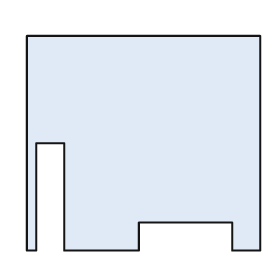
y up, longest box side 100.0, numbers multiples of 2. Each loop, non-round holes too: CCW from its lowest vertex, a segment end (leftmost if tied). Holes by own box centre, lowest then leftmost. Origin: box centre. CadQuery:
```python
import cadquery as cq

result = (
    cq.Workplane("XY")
    .moveTo(-50.0, -46.0)
    .lineTo(-46.0, -46.0)
    .lineTo(-46.0, 0.0)
    .lineTo(-34.0, 0.0)
    .lineTo(-34.0, -46.0)
    .lineTo(-2.0, -46.0)
    .lineTo(-2.0, -34.0)
    .lineTo(38.0, -34.0)
    .lineTo(38.0, -46.0)
    .lineTo(50.0, -46.0)
    .lineTo(50.0, 46.0)
    .lineTo(-50.0, 46.0)
    .close()
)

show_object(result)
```